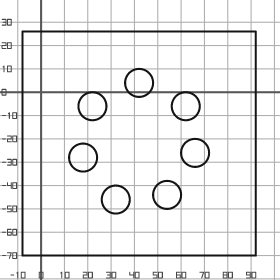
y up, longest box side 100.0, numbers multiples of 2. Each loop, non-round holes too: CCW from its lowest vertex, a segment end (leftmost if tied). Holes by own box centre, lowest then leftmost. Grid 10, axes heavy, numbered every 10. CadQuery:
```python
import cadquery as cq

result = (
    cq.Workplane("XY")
    .moveTo(-8.0, -70.0)
    .lineTo(92.0, -70.0)
    .lineTo(92.0, 26.0)
    .lineTo(-8.0, 26.0)
    .close()
    .moveTo(32.0, -46.0)
    .circle(6.0)
    .moveTo(54.0, -44.0)
    .circle(6.0)
    .moveTo(18.0, -28.0)
    .circle(6.0)
    .moveTo(66.0, -26.0)
    .circle(6.0)
    .moveTo(22.0, -6.0)
    .circle(6.0)
    .moveTo(62.0, -6.0)
    .circle(6.0)
    .moveTo(42.0, 4.0)
    .circle(6.0)
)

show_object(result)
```